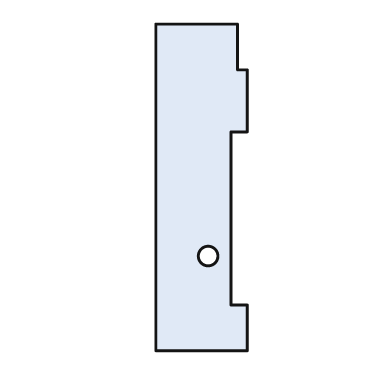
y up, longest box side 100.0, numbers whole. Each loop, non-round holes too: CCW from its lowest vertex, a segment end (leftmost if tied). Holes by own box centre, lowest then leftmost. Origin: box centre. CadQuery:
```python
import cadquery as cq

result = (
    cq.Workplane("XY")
    .moveTo(-14.0, -50.0)
    .lineTo(14.0, -50.0)
    .lineTo(14.0, -36.0)
    .lineTo(9.0, -36.0)
    .lineTo(9.0, 17.0)
    .lineTo(14.0, 17.0)
    .lineTo(14.0, 36.0)
    .lineTo(11.0, 36.0)
    .lineTo(11.0, 50.0)
    .lineTo(-14.0, 50.0)
    .close()
    .moveTo(2.0, -21.0)
    .circle(3.0)
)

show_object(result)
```